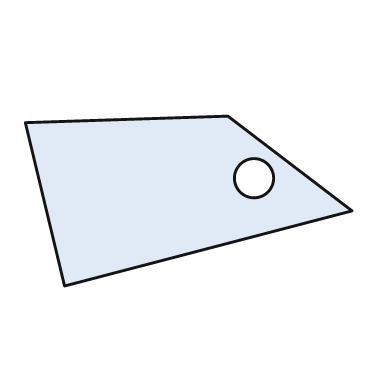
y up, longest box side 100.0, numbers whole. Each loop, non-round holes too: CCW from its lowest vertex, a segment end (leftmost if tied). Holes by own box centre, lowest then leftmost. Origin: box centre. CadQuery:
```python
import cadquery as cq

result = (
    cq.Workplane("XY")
    .moveTo(-38.0, -26.0)
    .lineTo(50.0, -3.0)
    .lineTo(12.0, 26.0)
    .lineTo(-50.0, 24.0)
    .close()
    .moveTo(20.0, 7.0)
    .circle(6.0)
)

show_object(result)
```